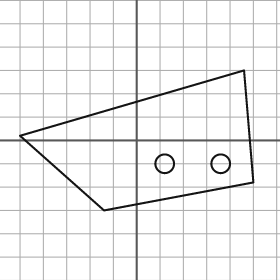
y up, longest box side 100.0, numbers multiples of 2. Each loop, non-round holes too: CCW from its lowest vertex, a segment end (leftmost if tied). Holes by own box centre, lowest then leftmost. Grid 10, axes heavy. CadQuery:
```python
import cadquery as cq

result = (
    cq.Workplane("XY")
    .moveTo(-14.0, -30.0)
    .lineTo(50.0, -18.0)
    .lineTo(46.0, 30.0)
    .lineTo(-50.0, 2.0)
    .close()
    .moveTo(12.0, -10.0)
    .circle(4.0)
    .moveTo(36.0, -10.0)
    .circle(4.0)
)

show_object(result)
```